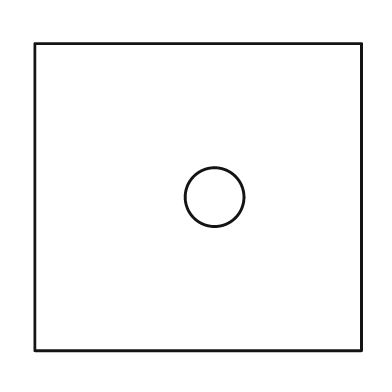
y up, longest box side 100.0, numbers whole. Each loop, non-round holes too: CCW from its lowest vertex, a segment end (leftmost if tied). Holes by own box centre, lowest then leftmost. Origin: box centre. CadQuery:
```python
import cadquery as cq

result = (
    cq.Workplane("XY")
    .moveTo(-50.0, -47.0)
    .lineTo(50.0, -47.0)
    .lineTo(50.0, 47.0)
    .lineTo(-50.0, 47.0)
    .close()
    .moveTo(5.0, 0.0)
    .circle(9.0)
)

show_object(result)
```